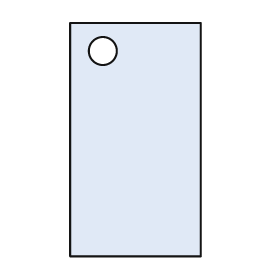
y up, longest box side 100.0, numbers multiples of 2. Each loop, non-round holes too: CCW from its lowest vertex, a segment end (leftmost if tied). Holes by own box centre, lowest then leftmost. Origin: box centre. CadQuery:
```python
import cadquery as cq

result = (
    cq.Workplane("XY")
    .moveTo(-28.0, -50.0)
    .lineTo(28.0, -50.0)
    .lineTo(28.0, 50.0)
    .lineTo(-28.0, 50.0)
    .close()
    .moveTo(-14.0, 38.0)
    .circle(6.0)
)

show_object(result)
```